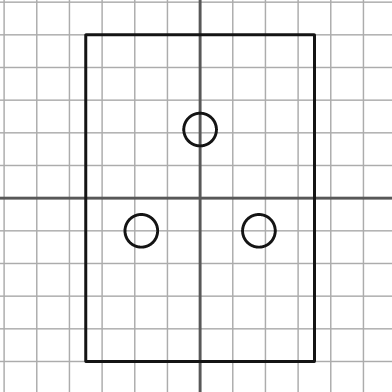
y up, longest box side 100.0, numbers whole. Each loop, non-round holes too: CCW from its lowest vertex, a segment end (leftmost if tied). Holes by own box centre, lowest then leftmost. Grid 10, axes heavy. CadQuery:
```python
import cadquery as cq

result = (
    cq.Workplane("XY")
    .moveTo(-35.0, -50.0)
    .lineTo(35.0, -50.0)
    .lineTo(35.0, 50.0)
    .lineTo(-35.0, 50.0)
    .close()
    .moveTo(-18.0, -10.0)
    .circle(5.0)
    .moveTo(18.0, -10.0)
    .circle(5.0)
    .moveTo(0.0, 21.0)
    .circle(5.0)
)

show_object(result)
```